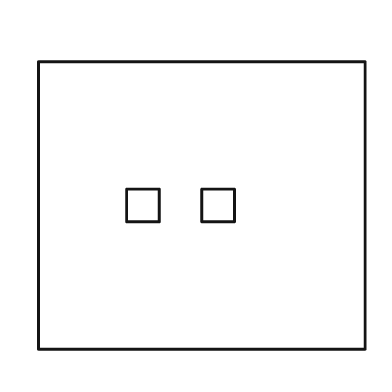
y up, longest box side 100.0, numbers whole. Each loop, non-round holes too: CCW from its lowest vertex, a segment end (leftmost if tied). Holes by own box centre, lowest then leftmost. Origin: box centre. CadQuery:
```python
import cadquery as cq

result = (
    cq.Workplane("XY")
    .moveTo(-50.0, -44.0)
    .lineTo(50.0, -44.0)
    .lineTo(50.0, 44.0)
    .lineTo(-50.0, 44.0)
    .close()
    .moveTo(-23.0, -5.0)
    .lineTo(-13.0, -5.0)
    .lineTo(-13.0, 5.0)
    .lineTo(-23.0, 5.0)
    .close()
    .moveTo(0.0, -5.0)
    .lineTo(10.0, -5.0)
    .lineTo(10.0, 5.0)
    .lineTo(0.0, 5.0)
    .close()
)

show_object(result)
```